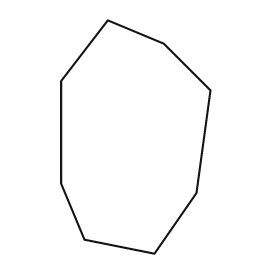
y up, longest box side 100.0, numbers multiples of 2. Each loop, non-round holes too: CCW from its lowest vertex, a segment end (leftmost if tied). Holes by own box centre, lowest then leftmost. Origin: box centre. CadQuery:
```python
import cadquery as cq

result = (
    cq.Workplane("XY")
    .moveTo(8.0, -50.0)
    .lineTo(26.0, -24.0)
    .lineTo(32.0, 20.0)
    .lineTo(12.0, 40.0)
    .lineTo(-12.0, 50.0)
    .lineTo(-32.0, 24.0)
    .lineTo(-32.0, -20.0)
    .lineTo(-22.0, -44.0)
    .close()
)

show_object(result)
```